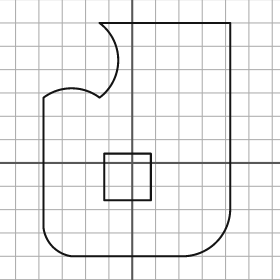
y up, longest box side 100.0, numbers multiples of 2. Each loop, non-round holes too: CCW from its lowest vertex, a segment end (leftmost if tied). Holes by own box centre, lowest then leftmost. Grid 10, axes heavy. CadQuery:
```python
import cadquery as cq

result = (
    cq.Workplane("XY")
    .moveTo(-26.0, -40.0)
    .lineTo(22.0, -40.0)
    .threePointArc((36.0, -34.0), (42.0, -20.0))
    .lineTo(42.0, 60.0)
    .lineTo(-14.0, 60.0)
    .threePointArc((-6.0, 44.0), (-14.0, 28.0))
    .threePointArc((-26.0, 32.0), (-38.0, 28.0))
    .lineTo(-38.0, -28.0)
    .threePointArc((-34.0, -36.0), (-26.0, -40.0))
    .close()
    .moveTo(-12.0, -16.0)
    .lineTo(8.0, -16.0)
    .lineTo(8.0, 4.0)
    .lineTo(-12.0, 4.0)
    .close()
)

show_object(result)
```